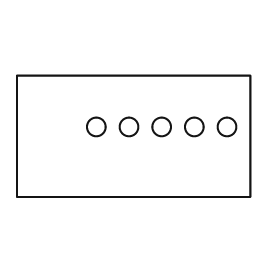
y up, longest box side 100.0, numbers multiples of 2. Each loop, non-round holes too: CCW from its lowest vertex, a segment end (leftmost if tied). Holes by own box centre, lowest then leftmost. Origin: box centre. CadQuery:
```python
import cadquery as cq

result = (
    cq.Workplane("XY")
    .moveTo(-50.0, -26.0)
    .lineTo(50.0, -26.0)
    .lineTo(50.0, 26.0)
    .lineTo(-50.0, 26.0)
    .close()
    .moveTo(-16.0, 4.0)
    .circle(4.0)
    .moveTo(-2.0, 4.0)
    .circle(4.0)
    .moveTo(12.0, 4.0)
    .circle(4.0)
    .moveTo(26.0, 4.0)
    .circle(4.0)
    .moveTo(40.0, 4.0)
    .circle(4.0)
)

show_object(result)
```